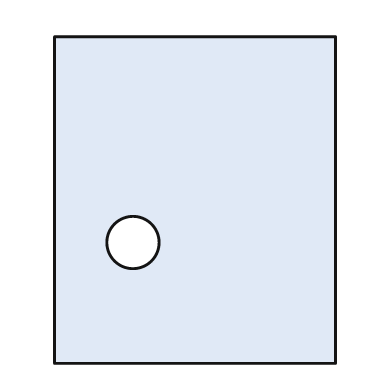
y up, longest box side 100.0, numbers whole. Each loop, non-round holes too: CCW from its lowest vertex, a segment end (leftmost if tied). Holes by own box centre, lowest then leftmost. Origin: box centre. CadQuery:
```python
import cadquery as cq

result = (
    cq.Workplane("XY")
    .moveTo(-43.0, -50.0)
    .lineTo(43.0, -50.0)
    .lineTo(43.0, 50.0)
    .lineTo(-43.0, 50.0)
    .close()
    .moveTo(-19.0, -13.0)
    .circle(8.0)
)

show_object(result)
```